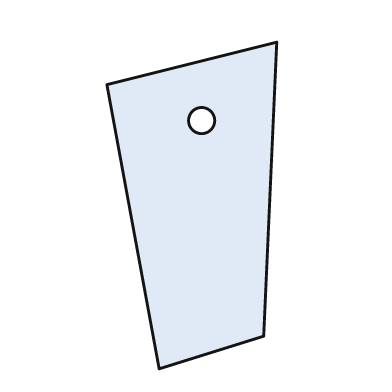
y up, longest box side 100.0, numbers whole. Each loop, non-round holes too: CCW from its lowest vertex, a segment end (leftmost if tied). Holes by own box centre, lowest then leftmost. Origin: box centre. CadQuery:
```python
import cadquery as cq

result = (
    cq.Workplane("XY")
    .moveTo(-10.0, -50.0)
    .lineTo(22.0, -40.0)
    .lineTo(26.0, 50.0)
    .lineTo(-26.0, 37.0)
    .close()
    .moveTo(3.0, 26.0)
    .circle(4.0)
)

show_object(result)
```